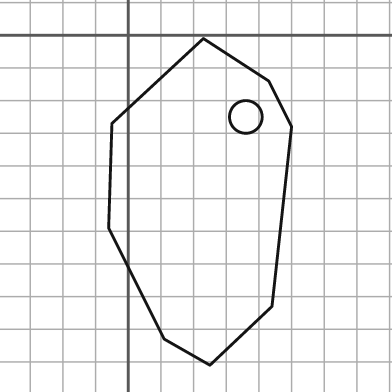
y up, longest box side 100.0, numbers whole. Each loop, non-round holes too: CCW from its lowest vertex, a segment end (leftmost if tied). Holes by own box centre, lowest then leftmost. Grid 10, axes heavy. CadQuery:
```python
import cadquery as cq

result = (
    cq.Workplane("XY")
    .moveTo(25.0, -101.0)
    .lineTo(44.0, -83.0)
    .lineTo(50.0, -28.0)
    .lineTo(43.0, -14.0)
    .lineTo(23.0, -1.0)
    .lineTo(-5.0, -27.0)
    .lineTo(-6.0, -59.0)
    .lineTo(11.0, -93.0)
    .close()
    .moveTo(36.0, -25.0)
    .circle(5.0)
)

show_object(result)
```